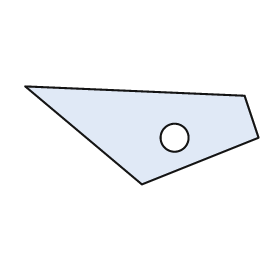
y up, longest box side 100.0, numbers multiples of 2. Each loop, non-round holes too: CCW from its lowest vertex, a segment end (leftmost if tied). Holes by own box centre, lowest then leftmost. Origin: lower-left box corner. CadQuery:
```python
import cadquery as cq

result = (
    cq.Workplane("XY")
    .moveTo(50.0, 0.0)
    .lineTo(100.0, 20.0)
    .lineTo(94.0, 38.0)
    .lineTo(0.0, 42.0)
    .close()
    .moveTo(64.0, 20.0)
    .circle(6.0)
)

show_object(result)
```